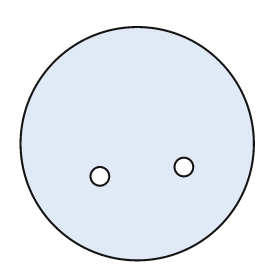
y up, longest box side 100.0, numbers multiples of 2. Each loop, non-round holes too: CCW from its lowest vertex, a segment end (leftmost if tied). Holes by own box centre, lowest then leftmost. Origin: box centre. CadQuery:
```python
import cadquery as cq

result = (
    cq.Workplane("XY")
    .moveTo(0.0, 0.0)
    .circle(50.0)
    .moveTo(-16.0, -14.0)
    .circle(4.0)
    .moveTo(20.0, -10.0)
    .circle(4.0)
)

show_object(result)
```